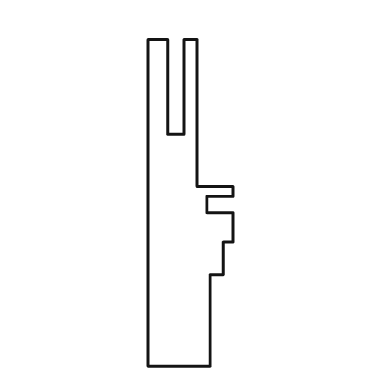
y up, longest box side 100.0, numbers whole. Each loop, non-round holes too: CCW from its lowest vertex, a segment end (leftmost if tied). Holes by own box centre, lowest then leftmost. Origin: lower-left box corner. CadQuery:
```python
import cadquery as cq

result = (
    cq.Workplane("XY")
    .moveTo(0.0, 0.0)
    .lineTo(19.0, 0.0)
    .lineTo(19.0, 28.0)
    .lineTo(23.0, 28.0)
    .lineTo(23.0, 38.0)
    .lineTo(26.0, 38.0)
    .lineTo(26.0, 47.0)
    .lineTo(18.0, 47.0)
    .lineTo(18.0, 52.0)
    .lineTo(26.0, 52.0)
    .lineTo(26.0, 55.0)
    .lineTo(15.0, 55.0)
    .lineTo(15.0, 100.0)
    .lineTo(11.0, 100.0)
    .lineTo(11.0, 71.0)
    .lineTo(6.0, 71.0)
    .lineTo(6.0, 100.0)
    .lineTo(0.0, 100.0)
    .close()
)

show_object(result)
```